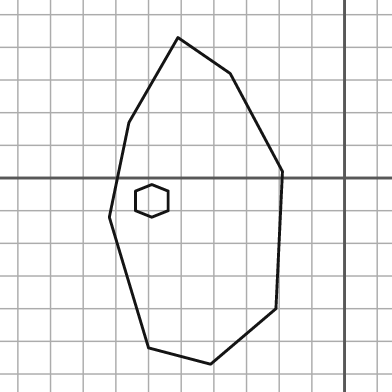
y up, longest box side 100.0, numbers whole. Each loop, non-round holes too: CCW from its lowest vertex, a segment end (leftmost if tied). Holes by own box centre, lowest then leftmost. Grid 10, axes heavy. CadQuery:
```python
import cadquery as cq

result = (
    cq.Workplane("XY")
    .moveTo(-41.0, -57.0)
    .lineTo(-21.0, -40.0)
    .lineTo(-19.0, 2.0)
    .lineTo(-35.0, 32.0)
    .lineTo(-51.0, 43.0)
    .lineTo(-66.0, 17.0)
    .lineTo(-72.0, -12.0)
    .lineTo(-60.0, -52.0)
    .close()
    .moveTo(-59.0, -12.0)
    .lineTo(-54.0, -10.0)
    .lineTo(-54.0, -4.0)
    .lineTo(-59.0, -2.0)
    .lineTo(-64.0, -4.0)
    .lineTo(-64.0, -10.0)
    .close()
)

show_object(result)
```